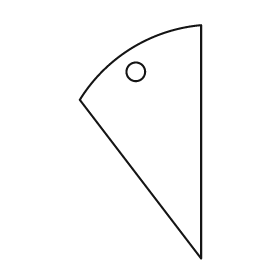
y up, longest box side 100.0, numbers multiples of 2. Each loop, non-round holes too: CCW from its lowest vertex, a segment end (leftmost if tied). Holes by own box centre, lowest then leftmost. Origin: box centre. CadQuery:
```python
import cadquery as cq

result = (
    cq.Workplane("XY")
    .moveTo(26.0, -50.0)
    .lineTo(26.0, 50.0)
    .threePointArc((-4.0, 40.0), (-26.0, 18.0))
    .close()
    .moveTo(-2.0, 30.0)
    .circle(4.0)
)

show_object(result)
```